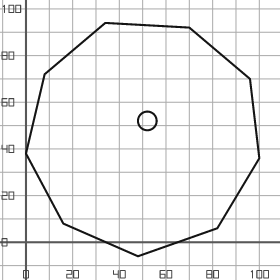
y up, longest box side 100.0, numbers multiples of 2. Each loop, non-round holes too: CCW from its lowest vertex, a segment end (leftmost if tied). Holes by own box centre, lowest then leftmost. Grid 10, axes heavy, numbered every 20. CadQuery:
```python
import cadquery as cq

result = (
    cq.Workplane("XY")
    .moveTo(48.0, -6.0)
    .lineTo(82.0, 6.0)
    .lineTo(100.0, 36.0)
    .lineTo(96.0, 70.0)
    .lineTo(70.0, 92.0)
    .lineTo(34.0, 94.0)
    .lineTo(8.0, 72.0)
    .lineTo(0.0, 38.0)
    .lineTo(16.0, 8.0)
    .close()
    .moveTo(52.0, 52.0)
    .circle(4.0)
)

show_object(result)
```